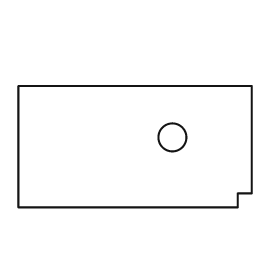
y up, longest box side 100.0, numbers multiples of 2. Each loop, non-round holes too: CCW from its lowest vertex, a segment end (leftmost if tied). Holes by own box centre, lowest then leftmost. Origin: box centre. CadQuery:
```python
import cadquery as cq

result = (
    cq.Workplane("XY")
    .moveTo(-50.0, -26.0)
    .lineTo(44.0, -26.0)
    .lineTo(44.0, -20.0)
    .lineTo(50.0, -20.0)
    .lineTo(50.0, 26.0)
    .lineTo(-50.0, 26.0)
    .close()
    .moveTo(16.0, 4.0)
    .circle(6.0)
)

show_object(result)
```